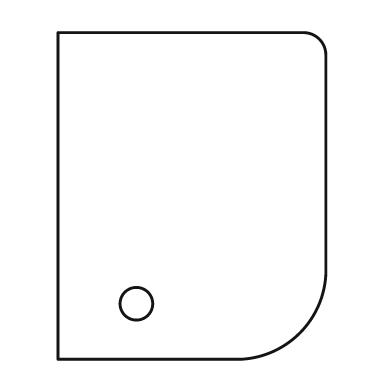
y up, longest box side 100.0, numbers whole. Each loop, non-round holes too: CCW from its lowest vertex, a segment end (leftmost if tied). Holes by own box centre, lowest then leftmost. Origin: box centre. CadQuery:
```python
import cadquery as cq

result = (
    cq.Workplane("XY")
    .moveTo(-41.0, -50.0)
    .lineTo(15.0, -50.0)
    .threePointArc((33.0, -42.0), (41.0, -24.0))
    .lineTo(41.0, 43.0)
    .threePointArc((39.0, 48.0), (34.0, 50.0))
    .lineTo(-41.0, 50.0)
    .close()
    .moveTo(-17.0, -33.0)
    .circle(5.0)
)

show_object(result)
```